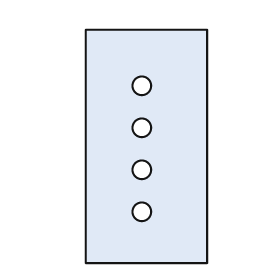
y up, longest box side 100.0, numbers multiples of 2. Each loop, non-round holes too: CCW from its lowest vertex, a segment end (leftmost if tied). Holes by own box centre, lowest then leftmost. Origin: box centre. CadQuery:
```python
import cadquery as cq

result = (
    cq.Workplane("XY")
    .moveTo(-26.0, -50.0)
    .lineTo(26.0, -50.0)
    .lineTo(26.0, 50.0)
    .lineTo(-26.0, 50.0)
    .close()
    .moveTo(-2.0, -28.0)
    .circle(4.0)
    .moveTo(-2.0, -10.0)
    .circle(4.0)
    .moveTo(-2.0, 8.0)
    .circle(4.0)
    .moveTo(-2.0, 26.0)
    .circle(4.0)
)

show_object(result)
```